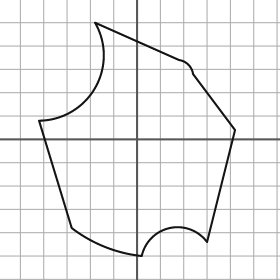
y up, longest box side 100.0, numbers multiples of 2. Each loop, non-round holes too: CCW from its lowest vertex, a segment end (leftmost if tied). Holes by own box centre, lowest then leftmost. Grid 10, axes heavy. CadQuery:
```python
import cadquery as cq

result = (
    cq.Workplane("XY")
    .moveTo(2.0, -50.0)
    .threePointArc((14.0, -38.0), (30.0, -44.0))
    .lineTo(42.0, 4.0)
    .lineTo(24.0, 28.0)
    .threePointArc((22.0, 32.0), (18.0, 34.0))
    .lineTo(-18.0, 50.0)
    .threePointArc((-18.0, 22.0), (-42.0, 8.0))
    .lineTo(-28.0, -38.0)
    .threePointArc((-14.0, -46.0), (2.0, -50.0))
    .close()
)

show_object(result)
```